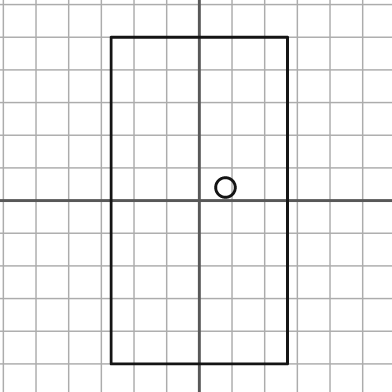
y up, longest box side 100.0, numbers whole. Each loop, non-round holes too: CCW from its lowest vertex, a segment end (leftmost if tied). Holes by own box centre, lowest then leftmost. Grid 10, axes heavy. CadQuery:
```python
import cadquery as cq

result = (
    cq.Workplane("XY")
    .moveTo(-27.0, -50.0)
    .lineTo(27.0, -50.0)
    .lineTo(27.0, 50.0)
    .lineTo(-27.0, 50.0)
    .close()
    .moveTo(8.0, 4.0)
    .circle(3.0)
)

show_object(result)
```